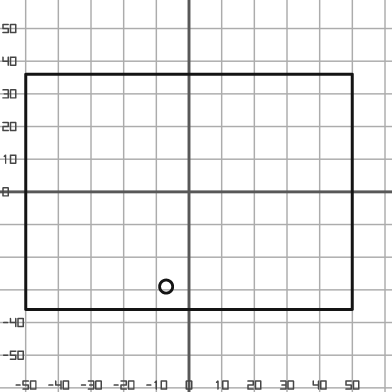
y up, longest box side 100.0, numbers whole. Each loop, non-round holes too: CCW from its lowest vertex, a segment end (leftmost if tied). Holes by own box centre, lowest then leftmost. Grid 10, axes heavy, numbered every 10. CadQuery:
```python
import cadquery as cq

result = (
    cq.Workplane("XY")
    .moveTo(-50.0, -36.0)
    .lineTo(50.0, -36.0)
    .lineTo(50.0, 36.0)
    .lineTo(-50.0, 36.0)
    .close()
    .moveTo(-7.0, -29.0)
    .circle(2.0)
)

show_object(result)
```